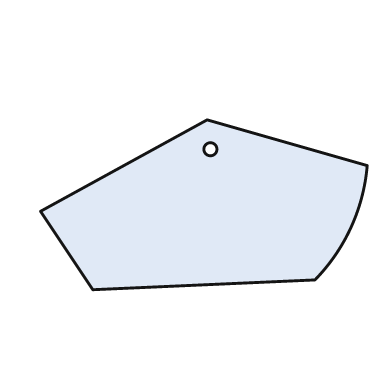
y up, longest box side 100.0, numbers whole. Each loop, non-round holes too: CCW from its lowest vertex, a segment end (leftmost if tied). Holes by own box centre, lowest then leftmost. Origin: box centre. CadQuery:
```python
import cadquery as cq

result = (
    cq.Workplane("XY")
    .moveTo(-34.0, -26.0)
    .lineTo(34.0, -23.0)
    .threePointArc((45.0, -7.0), (50.0, 12.0))
    .lineTo(1.0, 26.0)
    .lineTo(-50.0, -2.0)
    .close()
    .moveTo(2.0, 17.0)
    .circle(2.0)
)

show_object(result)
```